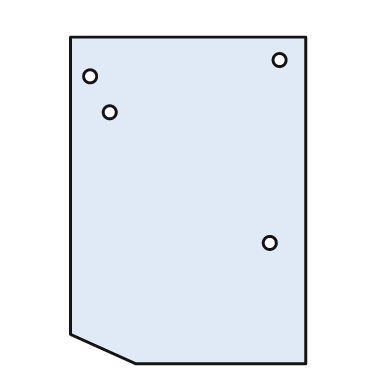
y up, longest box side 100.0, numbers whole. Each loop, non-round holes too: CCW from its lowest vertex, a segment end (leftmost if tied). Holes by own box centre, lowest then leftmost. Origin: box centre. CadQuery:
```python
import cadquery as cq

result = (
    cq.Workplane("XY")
    .moveTo(-16.0, -50.0)
    .lineTo(36.0, -50.0)
    .lineTo(36.0, 50.0)
    .lineTo(-36.0, 50.0)
    .lineTo(-36.0, -41.0)
    .close()
    .moveTo(25.0, -13.0)
    .circle(2.0)
    .moveTo(-24.0, 27.0)
    .circle(2.0)
    .moveTo(-30.0, 38.0)
    .circle(2.0)
    .moveTo(28.0, 43.0)
    .circle(2.0)
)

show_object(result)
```